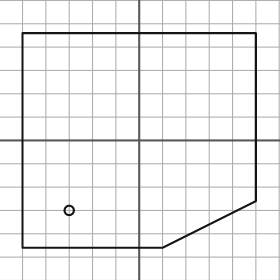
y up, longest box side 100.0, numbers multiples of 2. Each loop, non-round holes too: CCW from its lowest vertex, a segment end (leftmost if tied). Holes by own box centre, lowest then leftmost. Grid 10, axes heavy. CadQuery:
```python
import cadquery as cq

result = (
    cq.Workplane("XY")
    .moveTo(-50.0, -46.0)
    .lineTo(10.0, -46.0)
    .lineTo(50.0, -26.0)
    .lineTo(50.0, 46.0)
    .lineTo(-50.0, 46.0)
    .close()
    .moveTo(-30.0, -30.0)
    .circle(2.0)
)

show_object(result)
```